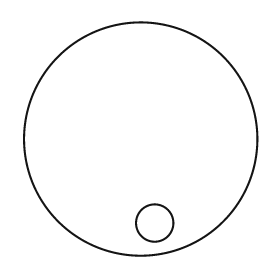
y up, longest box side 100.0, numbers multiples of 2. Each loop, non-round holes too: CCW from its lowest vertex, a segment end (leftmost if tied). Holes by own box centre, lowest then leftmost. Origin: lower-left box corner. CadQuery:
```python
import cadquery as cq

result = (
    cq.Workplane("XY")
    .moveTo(50.0, 50.0)
    .circle(50.0)
    .moveTo(56.0, 14.0)
    .circle(8.0)
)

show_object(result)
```